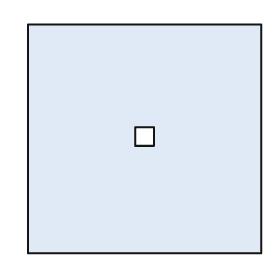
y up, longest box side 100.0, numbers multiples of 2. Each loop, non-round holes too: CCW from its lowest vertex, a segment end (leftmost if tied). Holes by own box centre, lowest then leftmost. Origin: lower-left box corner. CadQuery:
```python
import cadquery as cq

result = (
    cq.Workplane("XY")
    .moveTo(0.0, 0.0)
    .lineTo(100.0, 0.0)
    .lineTo(100.0, 98.0)
    .lineTo(0.0, 98.0)
    .close()
    .moveTo(46.0, 46.0)
    .lineTo(54.0, 46.0)
    .lineTo(54.0, 54.0)
    .lineTo(46.0, 54.0)
    .close()
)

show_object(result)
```